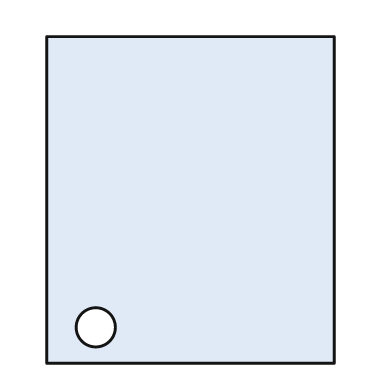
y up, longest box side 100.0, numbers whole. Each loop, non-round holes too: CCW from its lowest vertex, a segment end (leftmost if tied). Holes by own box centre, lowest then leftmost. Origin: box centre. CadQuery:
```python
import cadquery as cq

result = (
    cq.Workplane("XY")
    .moveTo(-44.0, -50.0)
    .lineTo(44.0, -50.0)
    .lineTo(44.0, 50.0)
    .lineTo(-44.0, 50.0)
    .close()
    .moveTo(-29.0, -39.0)
    .circle(6.0)
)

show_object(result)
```